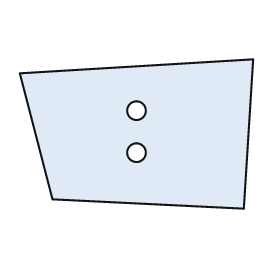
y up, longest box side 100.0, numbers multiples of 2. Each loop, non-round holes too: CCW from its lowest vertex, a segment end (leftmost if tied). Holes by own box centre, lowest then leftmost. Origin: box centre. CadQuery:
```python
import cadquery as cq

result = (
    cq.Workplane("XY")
    .moveTo(46.0, -32.0)
    .lineTo(50.0, 32.0)
    .lineTo(-50.0, 26.0)
    .lineTo(-36.0, -28.0)
    .close()
    .moveTo(0.0, -8.0)
    .circle(4.0)
    .moveTo(0.0, 10.0)
    .circle(4.0)
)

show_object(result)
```